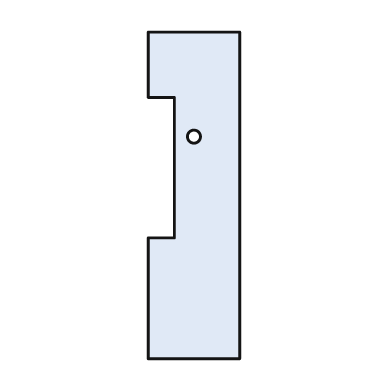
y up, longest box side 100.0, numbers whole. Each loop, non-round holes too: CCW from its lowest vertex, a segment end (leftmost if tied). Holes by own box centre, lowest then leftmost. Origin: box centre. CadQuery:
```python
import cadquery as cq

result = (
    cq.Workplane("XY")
    .moveTo(-14.0, -50.0)
    .lineTo(14.0, -50.0)
    .lineTo(14.0, 50.0)
    .lineTo(-14.0, 50.0)
    .lineTo(-14.0, 30.0)
    .lineTo(-6.0, 30.0)
    .lineTo(-6.0, -13.0)
    .lineTo(-14.0, -13.0)
    .close()
    .moveTo(0.0, 18.0)
    .circle(2.0)
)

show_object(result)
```